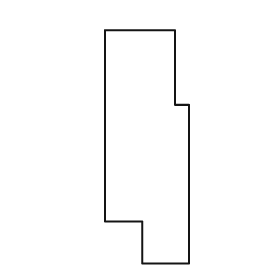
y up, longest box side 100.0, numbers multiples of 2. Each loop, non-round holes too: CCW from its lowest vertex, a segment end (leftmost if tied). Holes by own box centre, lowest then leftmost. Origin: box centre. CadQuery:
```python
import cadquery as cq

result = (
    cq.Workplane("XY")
    .moveTo(-2.0, -50.0)
    .lineTo(18.0, -50.0)
    .lineTo(18.0, 18.0)
    .lineTo(12.0, 18.0)
    .lineTo(12.0, 50.0)
    .lineTo(-18.0, 50.0)
    .lineTo(-18.0, -32.0)
    .lineTo(-2.0, -32.0)
    .close()
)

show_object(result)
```